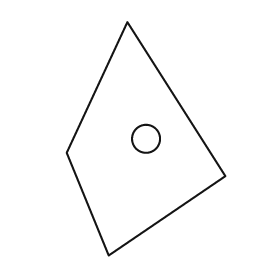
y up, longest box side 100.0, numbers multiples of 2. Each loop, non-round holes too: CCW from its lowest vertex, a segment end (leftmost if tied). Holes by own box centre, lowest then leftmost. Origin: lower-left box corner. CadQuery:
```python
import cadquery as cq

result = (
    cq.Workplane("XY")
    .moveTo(18.0, 0.0)
    .lineTo(68.0, 34.0)
    .lineTo(26.0, 100.0)
    .lineTo(0.0, 44.0)
    .close()
    .moveTo(34.0, 50.0)
    .circle(6.0)
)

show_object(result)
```